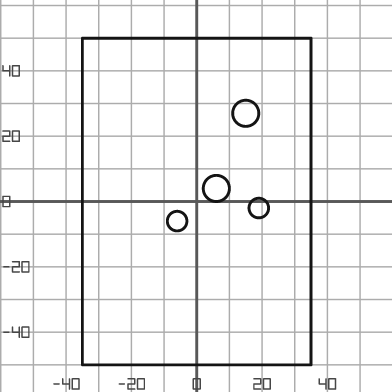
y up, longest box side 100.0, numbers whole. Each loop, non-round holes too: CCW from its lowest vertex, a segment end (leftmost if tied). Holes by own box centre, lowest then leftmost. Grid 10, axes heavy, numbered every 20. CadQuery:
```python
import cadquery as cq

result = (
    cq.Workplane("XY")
    .moveTo(-35.0, -50.0)
    .lineTo(35.0, -50.0)
    .lineTo(35.0, 50.0)
    .lineTo(-35.0, 50.0)
    .close()
    .moveTo(-6.0, -6.0)
    .circle(3.0)
    .moveTo(19.0, -2.0)
    .circle(3.0)
    .moveTo(6.0, 4.0)
    .circle(4.0)
    .moveTo(15.0, 27.0)
    .circle(4.0)
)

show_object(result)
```